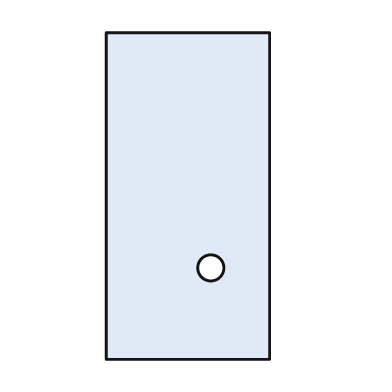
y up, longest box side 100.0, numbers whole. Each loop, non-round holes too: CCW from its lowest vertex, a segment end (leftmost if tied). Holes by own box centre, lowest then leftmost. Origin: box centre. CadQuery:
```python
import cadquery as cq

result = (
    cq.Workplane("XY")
    .moveTo(-25.0, -50.0)
    .lineTo(25.0, -50.0)
    .lineTo(25.0, 50.0)
    .lineTo(-25.0, 50.0)
    .close()
    .moveTo(7.0, -22.0)
    .circle(4.0)
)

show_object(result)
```